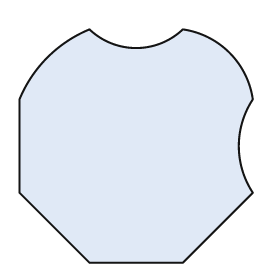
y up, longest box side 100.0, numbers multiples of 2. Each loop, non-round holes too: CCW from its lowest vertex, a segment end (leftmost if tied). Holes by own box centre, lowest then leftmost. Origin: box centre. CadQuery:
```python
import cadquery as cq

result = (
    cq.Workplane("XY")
    .moveTo(-20.0, -50.0)
    .lineTo(20.0, -50.0)
    .lineTo(50.0, -20.0)
    .threePointArc((44.0, 0.0), (50.0, 20.0))
    .threePointArc((40.0, 40.0), (20.0, 50.0))
    .threePointArc((0.0, 42.0), (-20.0, 50.0))
    .threePointArc((-38.0, 38.0), (-50.0, 20.0))
    .lineTo(-50.0, -20.0)
    .close()
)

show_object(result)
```